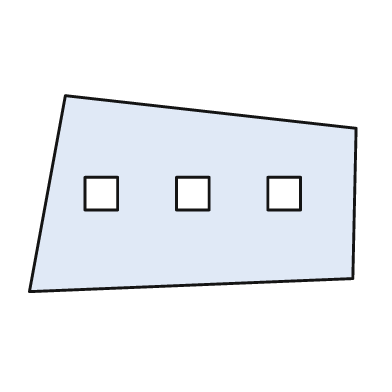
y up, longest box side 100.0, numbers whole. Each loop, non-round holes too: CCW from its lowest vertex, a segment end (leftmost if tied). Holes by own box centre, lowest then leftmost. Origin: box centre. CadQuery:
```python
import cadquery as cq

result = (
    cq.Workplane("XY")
    .moveTo(-50.0, -30.0)
    .lineTo(49.0, -26.0)
    .lineTo(50.0, 20.0)
    .lineTo(-39.0, 30.0)
    .close()
    .moveTo(-33.0, -5.0)
    .lineTo(-23.0, -5.0)
    .lineTo(-23.0, 5.0)
    .lineTo(-33.0, 5.0)
    .close()
    .moveTo(-5.0, -5.0)
    .lineTo(5.0, -5.0)
    .lineTo(5.0, 5.0)
    .lineTo(-5.0, 5.0)
    .close()
    .moveTo(23.0, -5.0)
    .lineTo(33.0, -5.0)
    .lineTo(33.0, 5.0)
    .lineTo(23.0, 5.0)
    .close()
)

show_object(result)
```